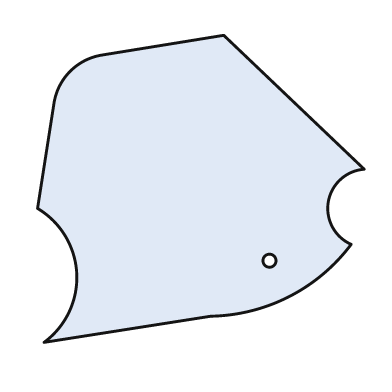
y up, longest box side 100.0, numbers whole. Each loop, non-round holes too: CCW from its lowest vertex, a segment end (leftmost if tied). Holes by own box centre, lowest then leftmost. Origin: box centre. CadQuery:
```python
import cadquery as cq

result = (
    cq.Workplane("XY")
    .moveTo(-48.0, -47.0)
    .lineTo(3.0, -39.0)
    .threePointArc((27.0, -33.0), (46.0, -17.0))
    .threePointArc((39.0, -4.0), (50.0, 6.0))
    .lineTo(7.0, 47.0)
    .lineTo(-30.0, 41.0)
    .threePointArc((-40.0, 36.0), (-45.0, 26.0))
    .lineTo(-50.0, -6.0)
    .threePointArc((-38.0, -26.0), (-48.0, -47.0))
    .close()
    .moveTo(21.0, -22.0)
    .circle(2.0)
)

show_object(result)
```